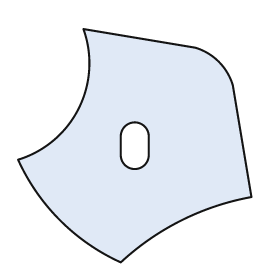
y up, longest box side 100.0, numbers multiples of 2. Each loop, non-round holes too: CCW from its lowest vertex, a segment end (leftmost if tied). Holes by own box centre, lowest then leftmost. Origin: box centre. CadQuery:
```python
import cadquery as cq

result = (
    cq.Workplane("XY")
    .moveTo(-6.0, -50.0)
    .threePointArc((20.0, -32.0), (50.0, -22.0))
    .lineTo(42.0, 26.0)
    .threePointArc((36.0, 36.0), (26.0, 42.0))
    .lineTo(-22.0, 50.0)
    .threePointArc((-24.0, 16.0), (-50.0, -6.0))
    .threePointArc((-32.0, -32.0), (-6.0, -50.0))
    .close()
    .moveTo(-6.0, -4.0)
    .threePointArc((0.0, -10.0), (6.0, -4.0))
    .lineTo(6.0, 4.0)
    .threePointArc((0.0, 10.0), (-6.0, 4.0))
    .close()
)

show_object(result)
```